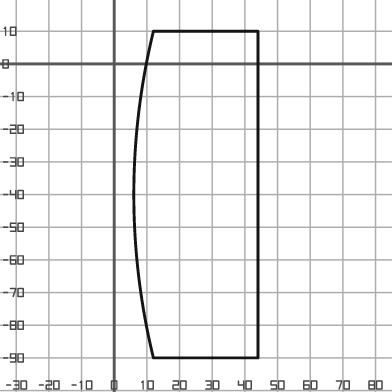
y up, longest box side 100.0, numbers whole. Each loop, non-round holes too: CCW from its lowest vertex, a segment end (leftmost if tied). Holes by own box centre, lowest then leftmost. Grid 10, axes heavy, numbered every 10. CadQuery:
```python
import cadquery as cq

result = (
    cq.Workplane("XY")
    .moveTo(12.0, -90.0)
    .lineTo(44.0, -90.0)
    .lineTo(44.0, 10.0)
    .lineTo(12.0, 10.0)
    .threePointArc((6.0, -40.0), (12.0, -90.0))
    .close()
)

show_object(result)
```